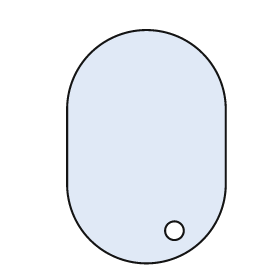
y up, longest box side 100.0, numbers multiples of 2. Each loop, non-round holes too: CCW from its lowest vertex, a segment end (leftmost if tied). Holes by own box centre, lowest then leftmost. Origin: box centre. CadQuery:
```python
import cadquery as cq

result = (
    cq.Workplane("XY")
    .moveTo(-34.0, -16.0)
    .threePointArc((0.0, -50.0), (34.0, -16.0))
    .lineTo(34.0, 16.0)
    .threePointArc((0.0, 50.0), (-34.0, 16.0))
    .close()
    .moveTo(12.0, -36.0)
    .circle(4.0)
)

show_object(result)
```